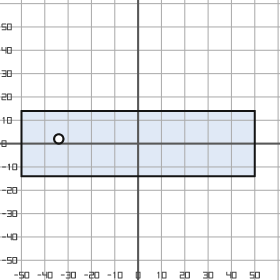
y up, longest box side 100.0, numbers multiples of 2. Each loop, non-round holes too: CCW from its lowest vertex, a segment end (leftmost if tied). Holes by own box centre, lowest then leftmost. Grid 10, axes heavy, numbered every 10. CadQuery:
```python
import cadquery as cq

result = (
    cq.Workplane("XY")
    .moveTo(-50.0, -14.0)
    .lineTo(50.0, -14.0)
    .lineTo(50.0, 14.0)
    .lineTo(-50.0, 14.0)
    .close()
    .moveTo(-34.0, 2.0)
    .circle(2.0)
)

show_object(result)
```